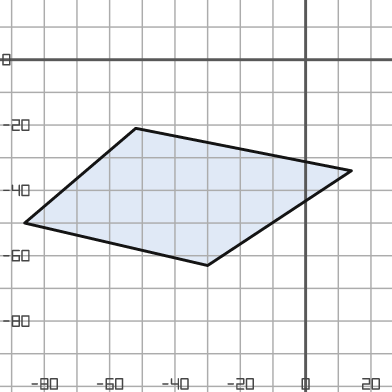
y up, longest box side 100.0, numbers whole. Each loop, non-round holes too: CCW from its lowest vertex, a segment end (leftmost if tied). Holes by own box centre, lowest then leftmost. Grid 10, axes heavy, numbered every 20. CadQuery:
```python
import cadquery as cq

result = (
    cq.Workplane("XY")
    .moveTo(-30.0, -63.0)
    .lineTo(14.0, -34.0)
    .lineTo(-52.0, -21.0)
    .lineTo(-86.0, -50.0)
    .close()
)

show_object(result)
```